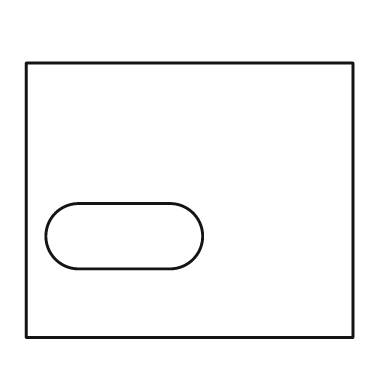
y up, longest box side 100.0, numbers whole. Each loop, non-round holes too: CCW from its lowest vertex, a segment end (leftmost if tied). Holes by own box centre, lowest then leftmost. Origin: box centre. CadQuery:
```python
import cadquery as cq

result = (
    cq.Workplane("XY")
    .moveTo(-50.0, -42.0)
    .lineTo(50.0, -42.0)
    .lineTo(50.0, 42.0)
    .lineTo(-50.0, 42.0)
    .close()
    .moveTo(-34.0, -21.0)
    .lineTo(-6.0, -21.0)
    .threePointArc((4.0, -11.0), (-6.0, -1.0))
    .lineTo(-34.0, -1.0)
    .threePointArc((-44.0, -11.0), (-34.0, -21.0))
    .close()
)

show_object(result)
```